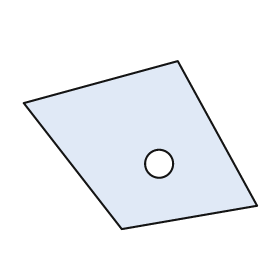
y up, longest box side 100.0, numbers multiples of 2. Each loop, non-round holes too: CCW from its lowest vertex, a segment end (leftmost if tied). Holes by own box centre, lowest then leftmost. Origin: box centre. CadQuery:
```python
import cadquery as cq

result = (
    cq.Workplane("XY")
    .moveTo(-8.0, -36.0)
    .lineTo(50.0, -26.0)
    .lineTo(16.0, 36.0)
    .lineTo(-50.0, 18.0)
    .close()
    .moveTo(8.0, -8.0)
    .circle(6.0)
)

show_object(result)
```